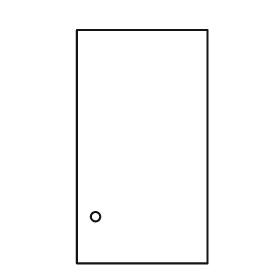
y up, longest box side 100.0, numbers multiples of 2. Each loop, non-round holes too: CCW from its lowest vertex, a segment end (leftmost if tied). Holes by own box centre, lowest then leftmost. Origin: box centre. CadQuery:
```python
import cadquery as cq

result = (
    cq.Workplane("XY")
    .moveTo(-28.0, -50.0)
    .lineTo(28.0, -50.0)
    .lineTo(28.0, 50.0)
    .lineTo(-28.0, 50.0)
    .close()
    .moveTo(-20.0, -30.0)
    .circle(2.0)
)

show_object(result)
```